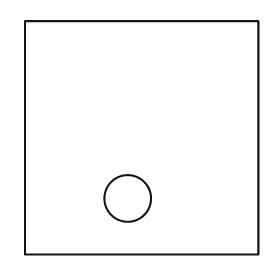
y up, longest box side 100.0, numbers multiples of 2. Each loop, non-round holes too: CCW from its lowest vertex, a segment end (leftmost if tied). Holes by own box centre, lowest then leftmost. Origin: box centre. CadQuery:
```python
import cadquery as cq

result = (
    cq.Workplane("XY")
    .moveTo(-50.0, -50.0)
    .lineTo(50.0, -50.0)
    .lineTo(50.0, 50.0)
    .lineTo(-50.0, 50.0)
    .close()
    .moveTo(-6.0, -26.0)
    .circle(10.0)
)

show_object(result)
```